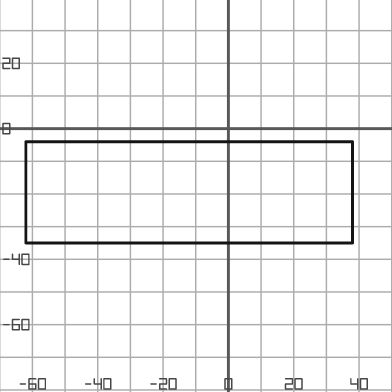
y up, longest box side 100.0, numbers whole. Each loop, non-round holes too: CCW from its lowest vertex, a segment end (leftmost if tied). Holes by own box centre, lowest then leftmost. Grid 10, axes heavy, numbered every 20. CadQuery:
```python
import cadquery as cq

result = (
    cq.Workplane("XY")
    .moveTo(-62.0, -35.0)
    .lineTo(38.0, -35.0)
    .lineTo(38.0, -4.0)
    .lineTo(-62.0, -4.0)
    .close()
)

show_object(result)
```